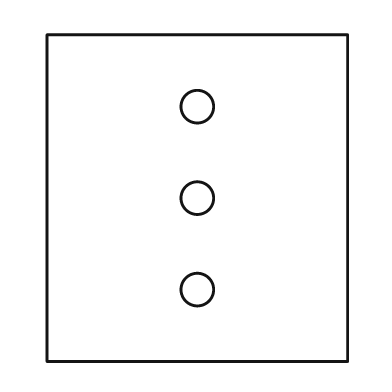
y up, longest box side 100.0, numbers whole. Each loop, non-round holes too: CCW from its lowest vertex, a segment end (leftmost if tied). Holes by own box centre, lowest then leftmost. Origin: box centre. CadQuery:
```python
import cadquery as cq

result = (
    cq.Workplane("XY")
    .moveTo(-46.0, -50.0)
    .lineTo(46.0, -50.0)
    .lineTo(46.0, 50.0)
    .lineTo(-46.0, 50.0)
    .close()
    .moveTo(0.0, -28.0)
    .circle(5.0)
    .moveTo(0.0, 0.0)
    .circle(5.0)
    .moveTo(0.0, 28.0)
    .circle(5.0)
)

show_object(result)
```